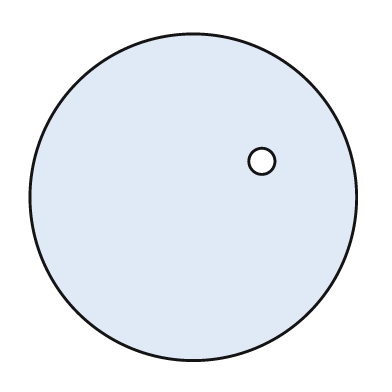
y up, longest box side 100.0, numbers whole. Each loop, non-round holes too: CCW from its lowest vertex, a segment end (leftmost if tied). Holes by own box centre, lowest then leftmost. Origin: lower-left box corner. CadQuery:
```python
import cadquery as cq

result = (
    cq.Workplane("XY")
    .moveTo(50.0, 50.0)
    .circle(50.0)
    .moveTo(71.0, 61.0)
    .circle(4.0)
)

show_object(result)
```